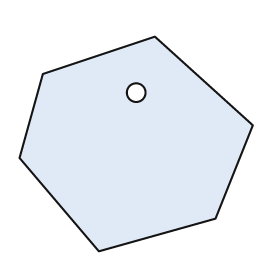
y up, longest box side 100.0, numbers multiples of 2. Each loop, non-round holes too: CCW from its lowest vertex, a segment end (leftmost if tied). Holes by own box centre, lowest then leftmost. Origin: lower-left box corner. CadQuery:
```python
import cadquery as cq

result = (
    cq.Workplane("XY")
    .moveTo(34.0, 0.0)
    .lineTo(84.0, 14.0)
    .lineTo(100.0, 54.0)
    .lineTo(58.0, 92.0)
    .lineTo(10.0, 76.0)
    .lineTo(0.0, 40.0)
    .close()
    .moveTo(50.0, 68.0)
    .circle(4.0)
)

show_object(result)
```